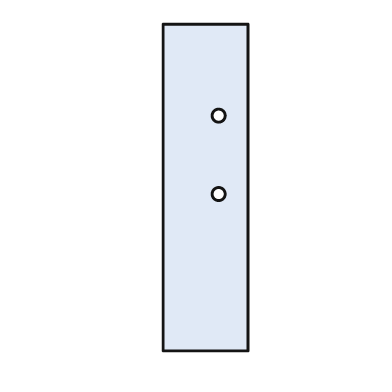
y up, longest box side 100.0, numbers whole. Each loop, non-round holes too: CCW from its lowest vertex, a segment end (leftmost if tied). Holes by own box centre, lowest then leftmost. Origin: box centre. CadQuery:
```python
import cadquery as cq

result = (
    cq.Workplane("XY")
    .moveTo(-13.0, -50.0)
    .lineTo(13.0, -50.0)
    .lineTo(13.0, 50.0)
    .lineTo(-13.0, 50.0)
    .close()
    .moveTo(4.0, -2.0)
    .circle(2.0)
    .moveTo(4.0, 22.0)
    .circle(2.0)
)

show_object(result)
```